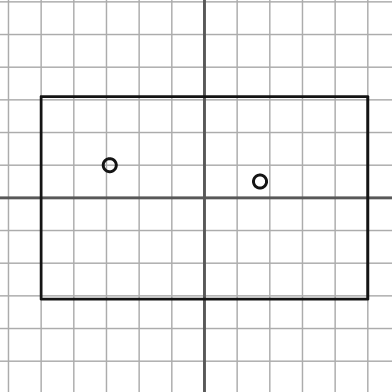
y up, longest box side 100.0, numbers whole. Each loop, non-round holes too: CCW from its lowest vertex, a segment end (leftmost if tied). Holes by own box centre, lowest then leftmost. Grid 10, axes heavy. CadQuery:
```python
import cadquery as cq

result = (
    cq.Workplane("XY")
    .moveTo(-50.0, -31.0)
    .lineTo(50.0, -31.0)
    .lineTo(50.0, 31.0)
    .lineTo(-50.0, 31.0)
    .close()
    .moveTo(17.0, 5.0)
    .circle(2.0)
    .moveTo(-29.0, 10.0)
    .circle(2.0)
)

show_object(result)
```